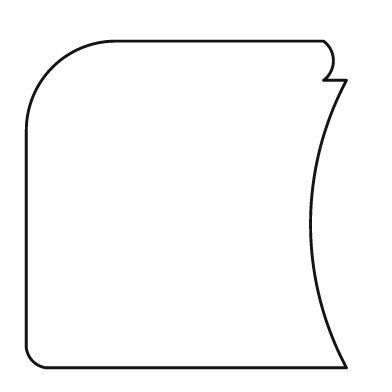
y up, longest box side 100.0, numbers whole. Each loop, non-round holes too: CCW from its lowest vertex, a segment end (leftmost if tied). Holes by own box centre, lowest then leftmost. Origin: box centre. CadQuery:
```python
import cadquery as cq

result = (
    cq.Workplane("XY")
    .moveTo(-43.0, -50.0)
    .lineTo(49.0, -50.0)
    .threePointArc((38.0, -6.0), (49.0, 38.0))
    .lineTo(42.0, 38.0)
    .threePointArc((45.0, 44.0), (42.0, 50.0))
    .lineTo(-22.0, 50.0)
    .threePointArc((-41.0, 42.0), (-49.0, 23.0))
    .lineTo(-49.0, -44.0)
    .threePointArc((-47.0, -48.0), (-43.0, -50.0))
    .close()
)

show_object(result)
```